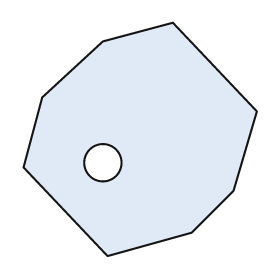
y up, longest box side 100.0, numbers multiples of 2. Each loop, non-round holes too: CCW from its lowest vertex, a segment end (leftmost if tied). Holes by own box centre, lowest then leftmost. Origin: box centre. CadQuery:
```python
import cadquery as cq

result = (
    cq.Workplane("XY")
    .moveTo(-14.0, -50.0)
    .lineTo(22.0, -40.0)
    .lineTo(40.0, -22.0)
    .lineTo(50.0, 12.0)
    .lineTo(14.0, 50.0)
    .lineTo(-16.0, 42.0)
    .lineTo(-42.0, 18.0)
    .lineTo(-50.0, -12.0)
    .close()
    .moveTo(-16.0, -10.0)
    .circle(8.0)
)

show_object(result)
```